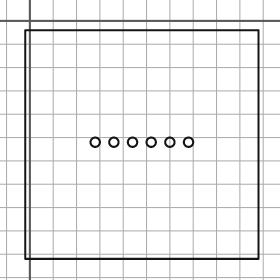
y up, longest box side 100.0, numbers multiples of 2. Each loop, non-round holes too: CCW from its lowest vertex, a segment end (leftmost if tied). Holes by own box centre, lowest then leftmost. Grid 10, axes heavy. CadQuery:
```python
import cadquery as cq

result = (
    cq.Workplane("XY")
    .moveTo(-2.0, -102.0)
    .lineTo(98.0, -102.0)
    .lineTo(98.0, -4.0)
    .lineTo(-2.0, -4.0)
    .close()
    .moveTo(28.0, -52.0)
    .circle(2.0)
    .moveTo(36.0, -52.0)
    .circle(2.0)
    .moveTo(44.0, -52.0)
    .circle(2.0)
    .moveTo(52.0, -52.0)
    .circle(2.0)
    .moveTo(60.0, -52.0)
    .circle(2.0)
    .moveTo(68.0, -52.0)
    .circle(2.0)
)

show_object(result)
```